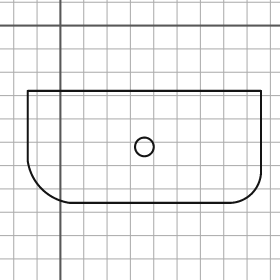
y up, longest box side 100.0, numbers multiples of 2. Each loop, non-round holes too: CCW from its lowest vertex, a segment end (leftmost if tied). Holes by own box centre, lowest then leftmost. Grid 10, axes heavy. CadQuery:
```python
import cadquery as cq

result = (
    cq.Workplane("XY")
    .moveTo(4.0, -76.0)
    .lineTo(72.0, -76.0)
    .threePointArc((82.0, -72.0), (86.0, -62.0))
    .lineTo(86.0, -28.0)
    .lineTo(-14.0, -28.0)
    .lineTo(-14.0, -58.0)
    .threePointArc((-8.0, -70.0), (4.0, -76.0))
    .close()
    .moveTo(36.0, -52.0)
    .circle(4.0)
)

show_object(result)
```